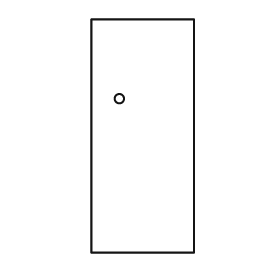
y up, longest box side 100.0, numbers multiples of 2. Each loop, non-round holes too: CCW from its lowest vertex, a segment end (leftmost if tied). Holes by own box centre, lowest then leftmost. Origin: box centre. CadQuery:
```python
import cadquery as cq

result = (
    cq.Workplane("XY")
    .moveTo(-22.0, -50.0)
    .lineTo(22.0, -50.0)
    .lineTo(22.0, 50.0)
    .lineTo(-22.0, 50.0)
    .close()
    .moveTo(-10.0, 16.0)
    .circle(2.0)
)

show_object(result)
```